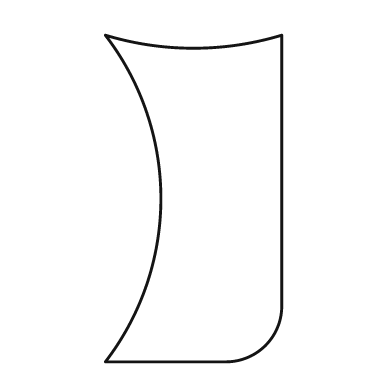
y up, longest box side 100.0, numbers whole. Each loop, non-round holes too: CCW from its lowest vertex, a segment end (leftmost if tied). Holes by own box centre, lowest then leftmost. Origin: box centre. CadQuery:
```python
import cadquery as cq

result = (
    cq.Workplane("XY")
    .moveTo(-27.0, -50.0)
    .lineTo(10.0, -50.0)
    .threePointArc((22.0, -45.0), (27.0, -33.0))
    .lineTo(27.0, 50.0)
    .threePointArc((0.0, 46.0), (-27.0, 50.0))
    .threePointArc((-10.0, 0.0), (-27.0, -50.0))
    .close()
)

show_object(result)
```